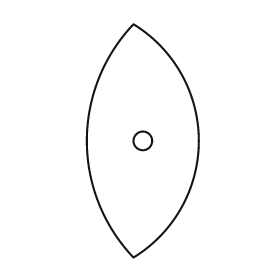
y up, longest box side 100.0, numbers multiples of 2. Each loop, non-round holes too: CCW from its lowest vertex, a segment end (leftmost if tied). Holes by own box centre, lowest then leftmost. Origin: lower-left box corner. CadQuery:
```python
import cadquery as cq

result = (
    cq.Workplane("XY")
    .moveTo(20.0, 0.0)
    .threePointArc((48.0, 50.0), (20.0, 100.0))
    .threePointArc((0.0, 50.0), (20.0, 0.0))
    .close()
    .moveTo(24.0, 50.0)
    .circle(4.0)
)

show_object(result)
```